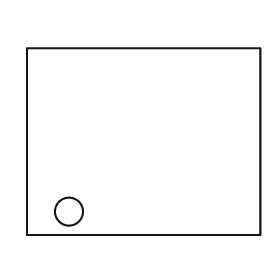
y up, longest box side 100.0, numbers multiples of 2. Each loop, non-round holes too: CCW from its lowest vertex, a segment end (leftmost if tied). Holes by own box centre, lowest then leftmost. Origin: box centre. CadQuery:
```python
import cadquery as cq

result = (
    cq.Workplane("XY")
    .moveTo(-50.0, -40.0)
    .lineTo(50.0, -40.0)
    .lineTo(50.0, 40.0)
    .lineTo(-50.0, 40.0)
    .close()
    .moveTo(-32.0, -30.0)
    .circle(6.0)
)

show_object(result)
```